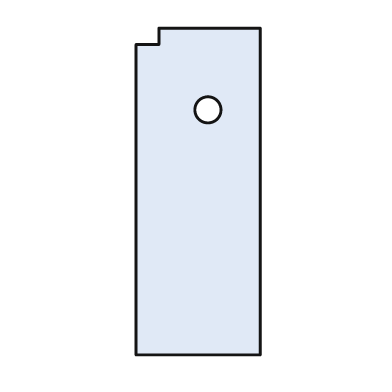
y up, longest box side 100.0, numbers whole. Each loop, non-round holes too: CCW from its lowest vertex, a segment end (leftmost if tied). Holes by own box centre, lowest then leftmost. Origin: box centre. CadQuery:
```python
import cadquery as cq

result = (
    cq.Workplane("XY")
    .moveTo(-19.0, -50.0)
    .lineTo(19.0, -50.0)
    .lineTo(19.0, 50.0)
    .lineTo(-12.0, 50.0)
    .lineTo(-12.0, 45.0)
    .lineTo(-19.0, 45.0)
    .close()
    .moveTo(3.0, 25.0)
    .circle(4.0)
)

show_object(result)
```